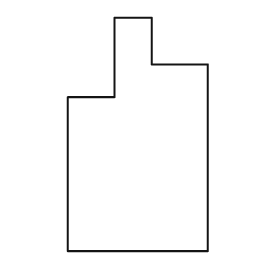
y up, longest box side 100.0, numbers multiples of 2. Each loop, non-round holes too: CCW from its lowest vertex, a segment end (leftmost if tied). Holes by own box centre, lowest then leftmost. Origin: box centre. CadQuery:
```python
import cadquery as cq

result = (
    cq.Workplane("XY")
    .moveTo(-30.0, -50.0)
    .lineTo(30.0, -50.0)
    .lineTo(30.0, 30.0)
    .lineTo(6.0, 30.0)
    .lineTo(6.0, 50.0)
    .lineTo(-10.0, 50.0)
    .lineTo(-10.0, 16.0)
    .lineTo(-30.0, 16.0)
    .close()
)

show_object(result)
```